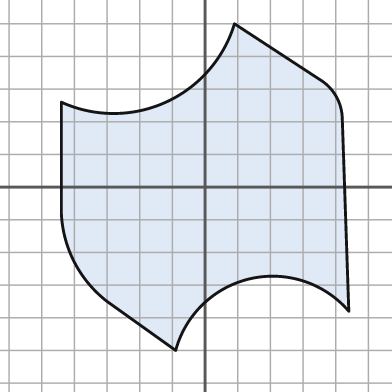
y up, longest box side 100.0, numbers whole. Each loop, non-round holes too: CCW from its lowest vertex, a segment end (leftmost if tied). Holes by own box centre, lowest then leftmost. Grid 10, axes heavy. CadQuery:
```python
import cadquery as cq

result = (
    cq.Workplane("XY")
    .moveTo(-9.0, -50.0)
    .threePointArc((14.0, -28.0), (44.0, -38.0))
    .lineTo(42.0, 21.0)
    .threePointArc((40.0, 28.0), (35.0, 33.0))
    .lineTo(9.0, 50.0)
    .threePointArc((-12.0, 26.0), (-44.0, 26.0))
    .lineTo(-44.0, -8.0)
    .threePointArc((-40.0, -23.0), (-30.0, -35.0))
    .close()
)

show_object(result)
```